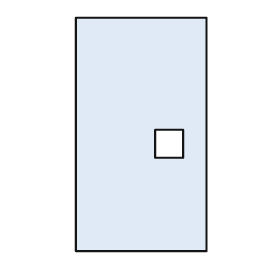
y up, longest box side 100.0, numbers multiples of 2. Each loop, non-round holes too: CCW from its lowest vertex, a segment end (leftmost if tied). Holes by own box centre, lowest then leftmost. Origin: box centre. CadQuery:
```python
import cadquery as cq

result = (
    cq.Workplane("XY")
    .moveTo(-28.0, -50.0)
    .lineTo(28.0, -50.0)
    .lineTo(28.0, 50.0)
    .lineTo(-28.0, 50.0)
    .close()
    .moveTo(6.0, -10.0)
    .lineTo(18.0, -10.0)
    .lineTo(18.0, 2.0)
    .lineTo(6.0, 2.0)
    .close()
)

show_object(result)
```